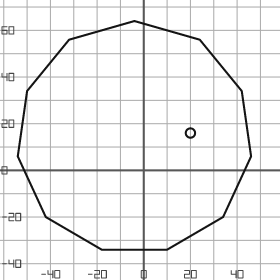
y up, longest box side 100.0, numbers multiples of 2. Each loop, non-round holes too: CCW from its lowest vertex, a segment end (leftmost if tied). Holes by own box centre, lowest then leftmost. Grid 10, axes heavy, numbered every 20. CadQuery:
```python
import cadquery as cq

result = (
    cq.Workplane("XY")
    .moveTo(-18.0, -34.0)
    .lineTo(10.0, -34.0)
    .lineTo(34.0, -20.0)
    .lineTo(46.0, 6.0)
    .lineTo(42.0, 34.0)
    .lineTo(24.0, 56.0)
    .lineTo(-4.0, 64.0)
    .lineTo(-32.0, 56.0)
    .lineTo(-50.0, 34.0)
    .lineTo(-54.0, 6.0)
    .lineTo(-42.0, -20.0)
    .close()
    .moveTo(20.0, 16.0)
    .circle(2.0)
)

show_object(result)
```